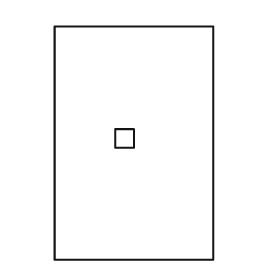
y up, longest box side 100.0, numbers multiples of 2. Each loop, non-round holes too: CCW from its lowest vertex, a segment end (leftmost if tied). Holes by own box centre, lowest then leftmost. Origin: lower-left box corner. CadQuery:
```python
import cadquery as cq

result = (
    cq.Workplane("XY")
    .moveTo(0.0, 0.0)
    .lineTo(68.0, 0.0)
    .lineTo(68.0, 100.0)
    .lineTo(0.0, 100.0)
    .close()
    .moveTo(26.0, 48.0)
    .lineTo(34.0, 48.0)
    .lineTo(34.0, 56.0)
    .lineTo(26.0, 56.0)
    .close()
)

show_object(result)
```